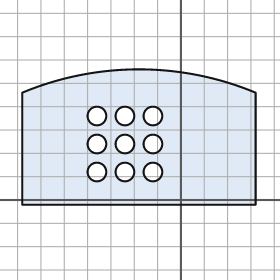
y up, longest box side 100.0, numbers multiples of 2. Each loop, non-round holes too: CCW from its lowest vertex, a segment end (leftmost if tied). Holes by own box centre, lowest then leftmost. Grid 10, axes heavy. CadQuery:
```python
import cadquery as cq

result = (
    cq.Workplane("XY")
    .moveTo(-68.0, -2.0)
    .lineTo(32.0, -2.0)
    .lineTo(32.0, 46.0)
    .threePointArc((-18.0, 56.0), (-68.0, 46.0))
    .close()
    .moveTo(-36.0, 12.0)
    .circle(4.0)
    .moveTo(-24.0, 12.0)
    .circle(4.0)
    .moveTo(-12.0, 12.0)
    .circle(4.0)
    .moveTo(-36.0, 24.0)
    .circle(4.0)
    .moveTo(-24.0, 24.0)
    .circle(4.0)
    .moveTo(-12.0, 24.0)
    .circle(4.0)
    .moveTo(-36.0, 36.0)
    .circle(4.0)
    .moveTo(-24.0, 36.0)
    .circle(4.0)
    .moveTo(-12.0, 36.0)
    .circle(4.0)
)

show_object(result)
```